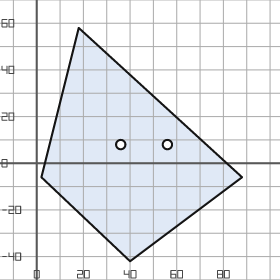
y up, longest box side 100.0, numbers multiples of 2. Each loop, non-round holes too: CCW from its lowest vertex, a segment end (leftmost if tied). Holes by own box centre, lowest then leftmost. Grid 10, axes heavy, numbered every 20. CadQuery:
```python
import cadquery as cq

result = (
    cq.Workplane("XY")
    .moveTo(40.0, -42.0)
    .lineTo(88.0, -6.0)
    .lineTo(18.0, 58.0)
    .lineTo(2.0, -6.0)
    .close()
    .moveTo(36.0, 8.0)
    .circle(2.0)
    .moveTo(56.0, 8.0)
    .circle(2.0)
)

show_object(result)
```